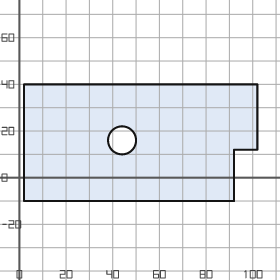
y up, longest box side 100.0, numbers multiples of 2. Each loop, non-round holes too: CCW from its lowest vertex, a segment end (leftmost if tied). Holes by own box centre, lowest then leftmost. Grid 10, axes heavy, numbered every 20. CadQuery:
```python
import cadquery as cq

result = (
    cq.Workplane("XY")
    .moveTo(2.0, -10.0)
    .lineTo(92.0, -10.0)
    .lineTo(92.0, 12.0)
    .lineTo(102.0, 12.0)
    .lineTo(102.0, 40.0)
    .lineTo(2.0, 40.0)
    .close()
    .moveTo(44.0, 16.0)
    .circle(6.0)
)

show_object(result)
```